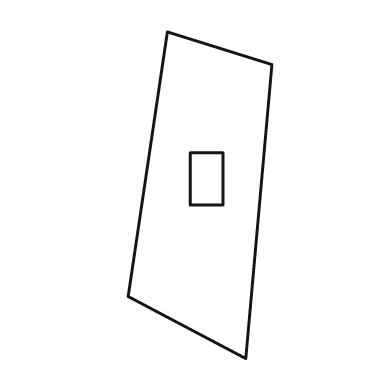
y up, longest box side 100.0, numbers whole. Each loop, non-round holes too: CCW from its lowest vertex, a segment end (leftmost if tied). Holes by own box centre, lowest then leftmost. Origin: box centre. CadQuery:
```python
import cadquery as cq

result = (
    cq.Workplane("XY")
    .moveTo(14.0, -50.0)
    .lineTo(22.0, 40.0)
    .lineTo(-10.0, 50.0)
    .lineTo(-22.0, -31.0)
    .close()
    .moveTo(-3.0, -3.0)
    .lineTo(7.0, -3.0)
    .lineTo(7.0, 13.0)
    .lineTo(-3.0, 13.0)
    .close()
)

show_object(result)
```